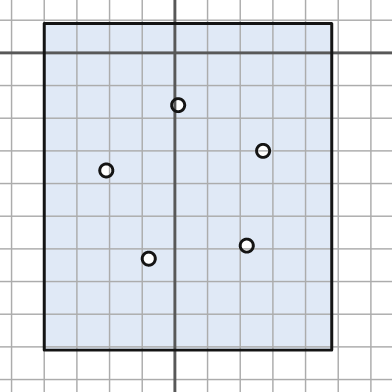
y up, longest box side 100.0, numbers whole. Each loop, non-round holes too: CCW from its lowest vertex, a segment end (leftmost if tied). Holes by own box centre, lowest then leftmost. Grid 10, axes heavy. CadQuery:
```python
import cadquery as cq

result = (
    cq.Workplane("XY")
    .moveTo(-40.0, -91.0)
    .lineTo(48.0, -91.0)
    .lineTo(48.0, 9.0)
    .lineTo(-40.0, 9.0)
    .close()
    .moveTo(-8.0, -63.0)
    .circle(2.0)
    .moveTo(22.0, -59.0)
    .circle(2.0)
    .moveTo(-21.0, -36.0)
    .circle(2.0)
    .moveTo(27.0, -30.0)
    .circle(2.0)
    .moveTo(1.0, -16.0)
    .circle(2.0)
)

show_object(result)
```